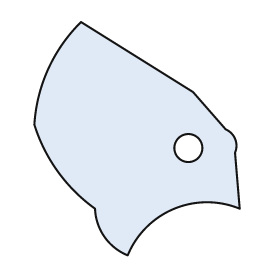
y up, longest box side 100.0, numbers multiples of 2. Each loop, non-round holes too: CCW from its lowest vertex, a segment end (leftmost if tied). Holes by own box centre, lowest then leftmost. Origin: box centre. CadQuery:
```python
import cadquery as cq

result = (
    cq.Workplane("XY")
    .moveTo(-4.0, -50.0)
    .threePointArc((16.0, -30.0), (44.0, -30.0))
    .lineTo(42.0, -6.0)
    .threePointArc((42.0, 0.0), (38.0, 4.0))
    .lineTo(24.0, 20.0)
    .lineTo(-24.0, 50.0)
    .threePointArc((-38.0, 30.0), (-44.0, 6.0))
    .threePointArc((-34.0, -14.0), (-18.0, -30.0))
    .threePointArc((-14.0, -42.0), (-4.0, -50.0))
    .close()
    .moveTo(22.0, -4.0)
    .circle(6.0)
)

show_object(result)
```